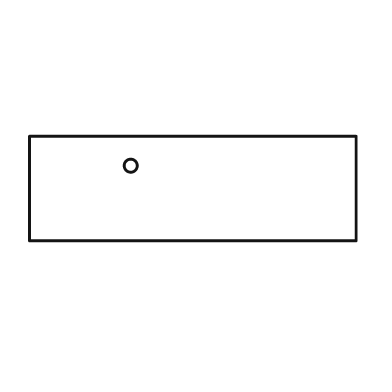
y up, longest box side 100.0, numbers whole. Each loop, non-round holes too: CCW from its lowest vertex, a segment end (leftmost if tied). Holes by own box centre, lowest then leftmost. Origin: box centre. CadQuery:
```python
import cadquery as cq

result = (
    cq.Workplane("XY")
    .moveTo(-50.0, -16.0)
    .lineTo(50.0, -16.0)
    .lineTo(50.0, 16.0)
    .lineTo(-50.0, 16.0)
    .close()
    .moveTo(-19.0, 7.0)
    .circle(2.0)
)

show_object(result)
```